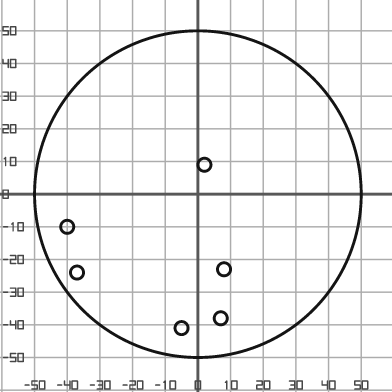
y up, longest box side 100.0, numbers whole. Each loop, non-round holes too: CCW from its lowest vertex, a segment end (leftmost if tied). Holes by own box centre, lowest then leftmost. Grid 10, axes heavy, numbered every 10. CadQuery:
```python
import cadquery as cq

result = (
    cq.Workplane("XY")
    .moveTo(0.0, 0.0)
    .circle(50.0)
    .moveTo(-5.0, -41.0)
    .circle(2.0)
    .moveTo(7.0, -38.0)
    .circle(2.0)
    .moveTo(-37.0, -24.0)
    .circle(2.0)
    .moveTo(8.0, -23.0)
    .circle(2.0)
    .moveTo(-40.0, -10.0)
    .circle(2.0)
    .moveTo(2.0, 9.0)
    .circle(2.0)
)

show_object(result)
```